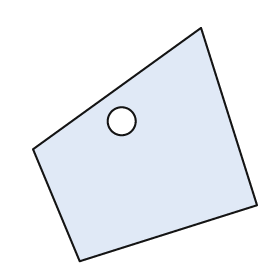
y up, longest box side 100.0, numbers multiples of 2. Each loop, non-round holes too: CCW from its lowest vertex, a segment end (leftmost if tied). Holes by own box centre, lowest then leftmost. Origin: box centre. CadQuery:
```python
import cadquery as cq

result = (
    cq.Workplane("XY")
    .moveTo(-28.0, -50.0)
    .lineTo(48.0, -26.0)
    .lineTo(24.0, 50.0)
    .lineTo(-48.0, -2.0)
    .close()
    .moveTo(-10.0, 10.0)
    .circle(6.0)
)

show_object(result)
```